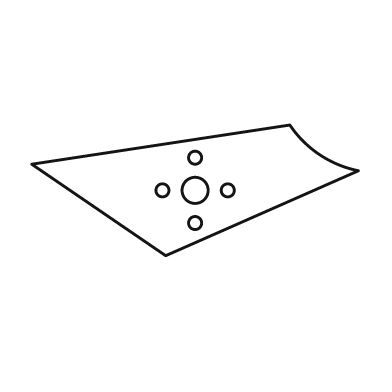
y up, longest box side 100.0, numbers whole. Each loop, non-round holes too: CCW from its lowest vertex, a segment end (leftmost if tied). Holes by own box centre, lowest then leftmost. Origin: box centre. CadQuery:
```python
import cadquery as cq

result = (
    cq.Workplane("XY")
    .moveTo(-9.0, -20.0)
    .lineTo(50.0, 6.0)
    .threePointArc((38.0, 11.0), (29.0, 20.0))
    .lineTo(-50.0, 8.0)
    .close()
    .moveTo(0.0, -10.0)
    .circle(2.0)
    .moveTo(-10.0, 0.0)
    .circle(2.0)
    .moveTo(0.0, 0.0)
    .circle(4.0)
    .moveTo(10.0, 0.0)
    .circle(2.0)
    .moveTo(0.0, 10.0)
    .circle(2.0)
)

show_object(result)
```